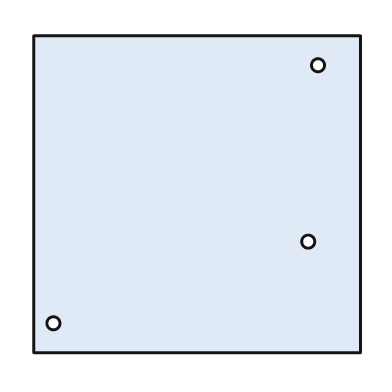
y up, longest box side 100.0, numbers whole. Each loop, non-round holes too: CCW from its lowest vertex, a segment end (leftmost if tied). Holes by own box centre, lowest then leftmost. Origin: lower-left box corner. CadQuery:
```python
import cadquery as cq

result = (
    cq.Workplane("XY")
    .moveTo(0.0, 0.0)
    .lineTo(100.0, 0.0)
    .lineTo(100.0, 97.0)
    .lineTo(0.0, 97.0)
    .close()
    .moveTo(6.0, 9.0)
    .circle(2.0)
    .moveTo(84.0, 34.0)
    .circle(2.0)
    .moveTo(87.0, 88.0)
    .circle(2.0)
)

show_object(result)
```